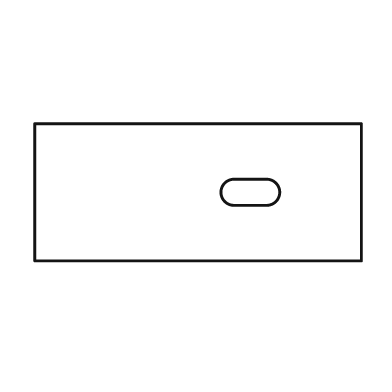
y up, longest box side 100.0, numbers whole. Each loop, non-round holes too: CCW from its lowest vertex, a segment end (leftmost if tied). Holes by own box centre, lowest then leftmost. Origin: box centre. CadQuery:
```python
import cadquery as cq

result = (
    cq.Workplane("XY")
    .moveTo(-50.0, -21.0)
    .lineTo(50.0, -21.0)
    .lineTo(50.0, 21.0)
    .lineTo(-50.0, 21.0)
    .close()
    .moveTo(11.0, -4.0)
    .lineTo(21.0, -4.0)
    .threePointArc((25.0, 0.0), (21.0, 4.0))
    .lineTo(11.0, 4.0)
    .threePointArc((7.0, 0.0), (11.0, -4.0))
    .close()
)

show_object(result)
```